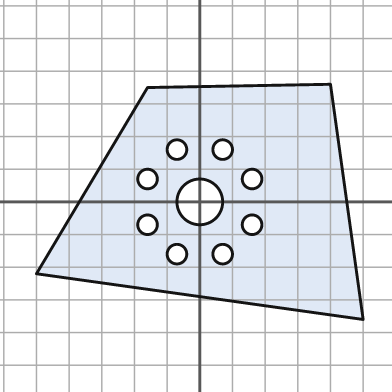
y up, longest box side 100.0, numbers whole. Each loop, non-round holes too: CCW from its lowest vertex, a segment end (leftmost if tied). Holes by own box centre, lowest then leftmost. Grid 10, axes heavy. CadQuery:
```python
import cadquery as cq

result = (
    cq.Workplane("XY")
    .moveTo(50.0, -36.0)
    .lineTo(40.0, 36.0)
    .lineTo(-16.0, 35.0)
    .lineTo(-50.0, -22.0)
    .close()
    .moveTo(-7.0, -16.0)
    .circle(3.0)
    .moveTo(7.0, -16.0)
    .circle(3.0)
    .moveTo(-16.0, -7.0)
    .circle(3.0)
    .moveTo(16.0, -7.0)
    .circle(3.0)
    .moveTo(0.0, 0.0)
    .circle(7.0)
    .moveTo(-16.0, 7.0)
    .circle(3.0)
    .moveTo(16.0, 7.0)
    .circle(3.0)
    .moveTo(-7.0, 16.0)
    .circle(3.0)
    .moveTo(7.0, 16.0)
    .circle(3.0)
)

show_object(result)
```